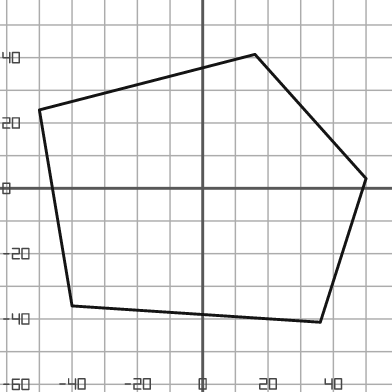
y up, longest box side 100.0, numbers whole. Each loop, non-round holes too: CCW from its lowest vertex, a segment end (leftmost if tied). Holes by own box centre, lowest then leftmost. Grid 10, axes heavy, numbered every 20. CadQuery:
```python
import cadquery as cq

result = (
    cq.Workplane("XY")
    .moveTo(36.0, -41.0)
    .lineTo(50.0, 3.0)
    .lineTo(16.0, 41.0)
    .lineTo(-50.0, 24.0)
    .lineTo(-40.0, -36.0)
    .close()
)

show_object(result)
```